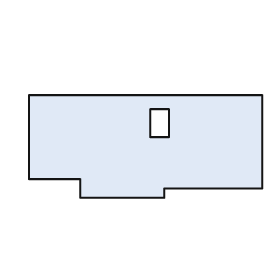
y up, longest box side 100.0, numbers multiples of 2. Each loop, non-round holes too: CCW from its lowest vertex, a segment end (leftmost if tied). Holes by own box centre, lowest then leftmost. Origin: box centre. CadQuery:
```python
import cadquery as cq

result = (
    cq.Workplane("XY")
    .moveTo(-28.0, -22.0)
    .lineTo(8.0, -22.0)
    .lineTo(8.0, -18.0)
    .lineTo(50.0, -18.0)
    .lineTo(50.0, 22.0)
    .lineTo(-50.0, 22.0)
    .lineTo(-50.0, -14.0)
    .lineTo(-28.0, -14.0)
    .close()
    .moveTo(2.0, 4.0)
    .lineTo(10.0, 4.0)
    .lineTo(10.0, 16.0)
    .lineTo(2.0, 16.0)
    .close()
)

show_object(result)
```